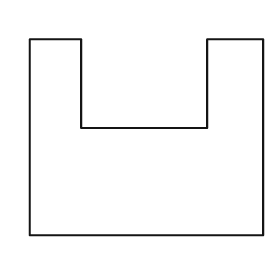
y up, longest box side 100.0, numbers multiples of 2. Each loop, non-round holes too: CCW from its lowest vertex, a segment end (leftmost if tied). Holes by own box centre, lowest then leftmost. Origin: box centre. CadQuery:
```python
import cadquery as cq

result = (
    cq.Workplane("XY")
    .moveTo(-50.0, -42.0)
    .lineTo(50.0, -42.0)
    .lineTo(50.0, 42.0)
    .lineTo(26.0, 42.0)
    .lineTo(26.0, 4.0)
    .lineTo(-28.0, 4.0)
    .lineTo(-28.0, 42.0)
    .lineTo(-50.0, 42.0)
    .close()
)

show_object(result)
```